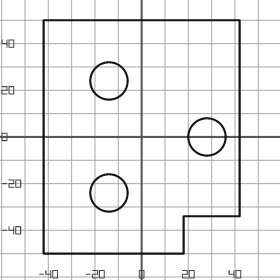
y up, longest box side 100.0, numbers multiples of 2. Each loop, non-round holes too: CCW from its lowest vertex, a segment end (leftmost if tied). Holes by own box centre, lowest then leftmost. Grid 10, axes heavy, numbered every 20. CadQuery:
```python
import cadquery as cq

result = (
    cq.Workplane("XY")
    .moveTo(-42.0, -50.0)
    .lineTo(18.0, -50.0)
    .lineTo(18.0, -34.0)
    .lineTo(42.0, -34.0)
    .lineTo(42.0, 50.0)
    .lineTo(-42.0, 50.0)
    .close()
    .moveTo(-14.0, -24.0)
    .circle(8.0)
    .moveTo(28.0, 0.0)
    .circle(8.0)
    .moveTo(-14.0, 24.0)
    .circle(8.0)
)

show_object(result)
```